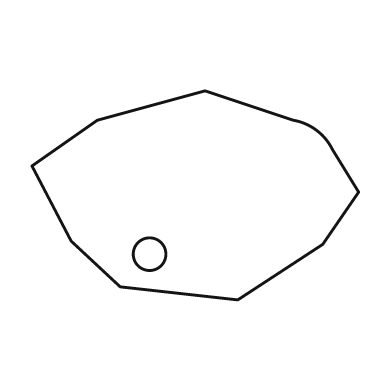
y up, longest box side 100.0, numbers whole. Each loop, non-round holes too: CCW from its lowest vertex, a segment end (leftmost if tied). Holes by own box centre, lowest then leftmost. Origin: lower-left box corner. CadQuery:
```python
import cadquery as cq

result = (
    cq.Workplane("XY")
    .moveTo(63.0, 0.0)
    .lineTo(89.0, 17.0)
    .lineTo(100.0, 33.0)
    .lineTo(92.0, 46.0)
    .threePointArc((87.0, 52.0), (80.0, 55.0))
    .lineTo(53.0, 64.0)
    .lineTo(20.0, 55.0)
    .lineTo(0.0, 41.0)
    .lineTo(12.0, 18.0)
    .lineTo(27.0, 4.0)
    .close()
    .moveTo(36.0, 14.0)
    .circle(5.0)
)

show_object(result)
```